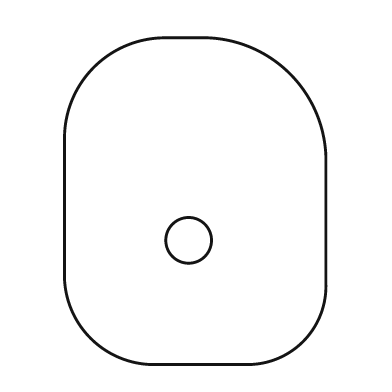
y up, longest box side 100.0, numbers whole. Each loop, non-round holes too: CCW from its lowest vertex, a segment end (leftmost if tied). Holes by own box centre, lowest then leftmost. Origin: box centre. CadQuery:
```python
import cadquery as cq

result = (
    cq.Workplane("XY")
    .moveTo(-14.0, -50.0)
    .lineTo(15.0, -50.0)
    .threePointArc((33.0, -43.0), (40.0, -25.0))
    .lineTo(40.0, 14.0)
    .threePointArc((29.0, 39.0), (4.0, 50.0))
    .lineTo(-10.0, 50.0)
    .threePointArc((-31.0, 41.0), (-40.0, 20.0))
    .lineTo(-40.0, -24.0)
    .threePointArc((-32.0, -42.0), (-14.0, -50.0))
    .close()
    .moveTo(-2.0, -12.0)
    .circle(7.0)
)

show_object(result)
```